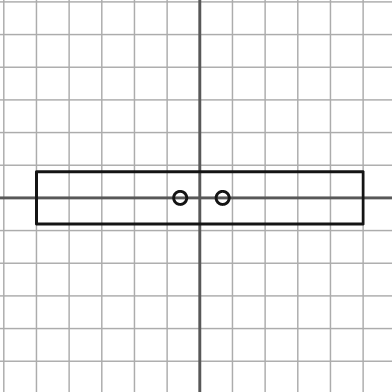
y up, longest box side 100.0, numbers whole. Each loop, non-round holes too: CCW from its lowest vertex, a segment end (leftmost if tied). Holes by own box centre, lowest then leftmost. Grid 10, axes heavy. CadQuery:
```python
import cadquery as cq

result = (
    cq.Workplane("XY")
    .moveTo(-50.0, -8.0)
    .lineTo(50.0, -8.0)
    .lineTo(50.0, 8.0)
    .lineTo(-50.0, 8.0)
    .close()
    .moveTo(-6.0, 0.0)
    .circle(2.0)
    .moveTo(7.0, 0.0)
    .circle(2.0)
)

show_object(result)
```